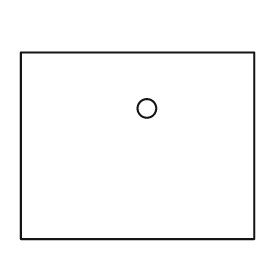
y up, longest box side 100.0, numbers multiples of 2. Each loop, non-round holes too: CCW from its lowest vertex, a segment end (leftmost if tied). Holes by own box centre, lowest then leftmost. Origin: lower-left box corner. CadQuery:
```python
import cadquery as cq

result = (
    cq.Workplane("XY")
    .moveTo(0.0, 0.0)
    .lineTo(100.0, 0.0)
    .lineTo(100.0, 80.0)
    .lineTo(0.0, 80.0)
    .close()
    .moveTo(54.0, 56.0)
    .circle(4.0)
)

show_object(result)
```